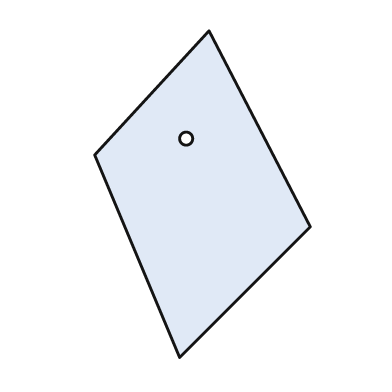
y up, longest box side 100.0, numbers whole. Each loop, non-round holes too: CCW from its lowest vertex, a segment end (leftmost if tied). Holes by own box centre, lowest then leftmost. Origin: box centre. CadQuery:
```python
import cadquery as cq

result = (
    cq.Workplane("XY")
    .moveTo(-7.0, -50.0)
    .lineTo(33.0, -10.0)
    .lineTo(2.0, 50.0)
    .lineTo(-33.0, 12.0)
    .close()
    .moveTo(-5.0, 17.0)
    .circle(2.0)
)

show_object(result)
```